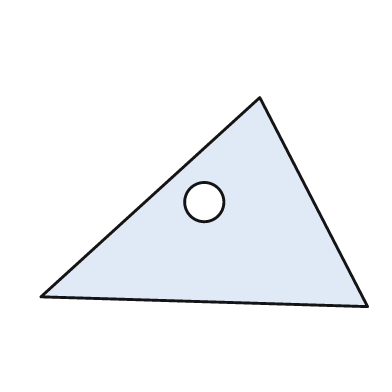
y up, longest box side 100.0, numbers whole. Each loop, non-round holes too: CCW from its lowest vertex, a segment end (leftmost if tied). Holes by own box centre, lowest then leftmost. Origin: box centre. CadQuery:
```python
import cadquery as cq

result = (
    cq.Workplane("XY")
    .moveTo(50.0, -32.0)
    .lineTo(17.0, 32.0)
    .lineTo(-50.0, -29.0)
    .close()
    .moveTo(0.0, 0.0)
    .circle(6.0)
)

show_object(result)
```